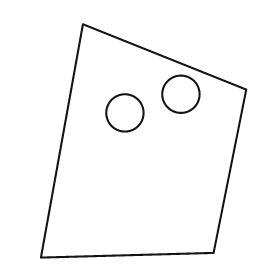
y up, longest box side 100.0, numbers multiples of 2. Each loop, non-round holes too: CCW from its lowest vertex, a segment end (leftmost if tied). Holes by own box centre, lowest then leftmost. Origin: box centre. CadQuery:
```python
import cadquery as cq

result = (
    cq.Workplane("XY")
    .moveTo(-44.0, -50.0)
    .lineTo(30.0, -48.0)
    .lineTo(44.0, 22.0)
    .lineTo(-26.0, 50.0)
    .close()
    .moveTo(-8.0, 12.0)
    .circle(8.0)
    .moveTo(16.0, 20.0)
    .circle(8.0)
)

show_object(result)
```